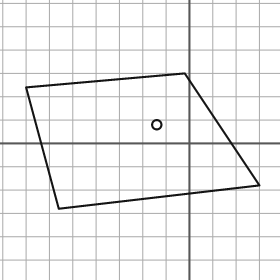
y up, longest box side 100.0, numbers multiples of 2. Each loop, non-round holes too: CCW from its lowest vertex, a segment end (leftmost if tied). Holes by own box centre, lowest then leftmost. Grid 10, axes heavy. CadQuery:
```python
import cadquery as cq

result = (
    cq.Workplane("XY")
    .moveTo(-56.0, -28.0)
    .lineTo(30.0, -18.0)
    .lineTo(-2.0, 30.0)
    .lineTo(-70.0, 24.0)
    .close()
    .moveTo(-14.0, 8.0)
    .circle(2.0)
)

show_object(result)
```